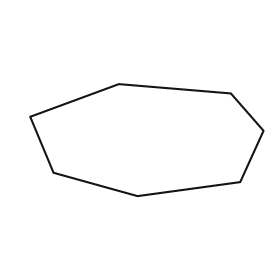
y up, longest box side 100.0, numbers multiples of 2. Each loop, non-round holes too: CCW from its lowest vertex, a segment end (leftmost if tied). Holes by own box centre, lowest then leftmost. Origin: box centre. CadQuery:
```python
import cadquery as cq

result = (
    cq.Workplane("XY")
    .moveTo(-4.0, -24.0)
    .lineTo(40.0, -18.0)
    .lineTo(50.0, 4.0)
    .lineTo(36.0, 20.0)
    .lineTo(-12.0, 24.0)
    .lineTo(-50.0, 10.0)
    .lineTo(-40.0, -14.0)
    .close()
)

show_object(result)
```